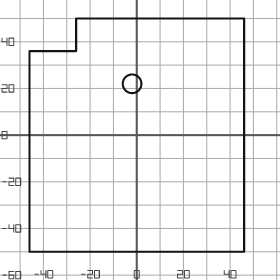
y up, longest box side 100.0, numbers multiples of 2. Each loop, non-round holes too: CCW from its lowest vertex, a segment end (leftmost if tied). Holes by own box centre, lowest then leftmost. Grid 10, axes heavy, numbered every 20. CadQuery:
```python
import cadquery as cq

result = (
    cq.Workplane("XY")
    .moveTo(-46.0, -50.0)
    .lineTo(46.0, -50.0)
    .lineTo(46.0, 50.0)
    .lineTo(-26.0, 50.0)
    .lineTo(-26.0, 36.0)
    .lineTo(-46.0, 36.0)
    .close()
    .moveTo(-2.0, 22.0)
    .circle(4.0)
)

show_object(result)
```